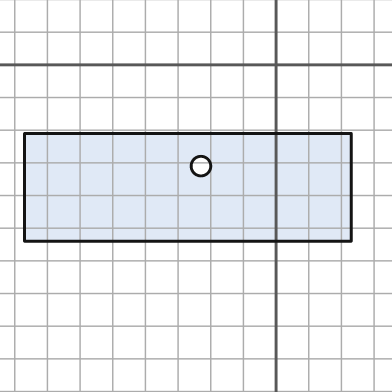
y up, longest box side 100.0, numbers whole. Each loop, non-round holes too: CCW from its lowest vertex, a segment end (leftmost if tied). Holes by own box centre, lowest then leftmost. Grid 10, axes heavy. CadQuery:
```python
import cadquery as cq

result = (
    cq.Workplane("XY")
    .moveTo(-77.0, -54.0)
    .lineTo(23.0, -54.0)
    .lineTo(23.0, -21.0)
    .lineTo(-77.0, -21.0)
    .close()
    .moveTo(-23.0, -31.0)
    .circle(3.0)
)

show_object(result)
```